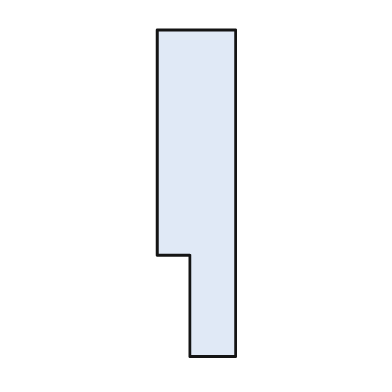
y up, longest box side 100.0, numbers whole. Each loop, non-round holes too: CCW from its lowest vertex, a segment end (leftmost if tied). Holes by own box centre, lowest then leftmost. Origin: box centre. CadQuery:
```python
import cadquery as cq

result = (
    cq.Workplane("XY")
    .moveTo(-2.0, -50.0)
    .lineTo(12.0, -50.0)
    .lineTo(12.0, 50.0)
    .lineTo(-12.0, 50.0)
    .lineTo(-12.0, -19.0)
    .lineTo(-2.0, -19.0)
    .close()
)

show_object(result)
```